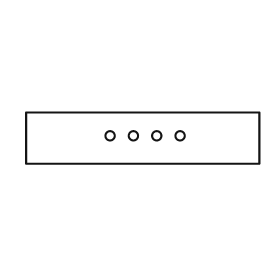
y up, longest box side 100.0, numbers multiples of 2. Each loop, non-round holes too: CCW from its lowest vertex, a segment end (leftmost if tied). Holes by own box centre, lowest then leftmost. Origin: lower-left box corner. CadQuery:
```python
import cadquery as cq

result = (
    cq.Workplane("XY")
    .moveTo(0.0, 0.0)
    .lineTo(100.0, 0.0)
    .lineTo(100.0, 22.0)
    .lineTo(0.0, 22.0)
    .close()
    .moveTo(36.0, 12.0)
    .circle(2.0)
    .moveTo(46.0, 12.0)
    .circle(2.0)
    .moveTo(56.0, 12.0)
    .circle(2.0)
    .moveTo(66.0, 12.0)
    .circle(2.0)
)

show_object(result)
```